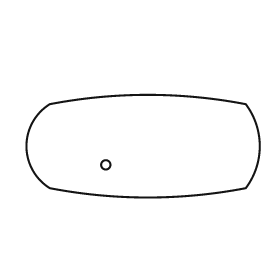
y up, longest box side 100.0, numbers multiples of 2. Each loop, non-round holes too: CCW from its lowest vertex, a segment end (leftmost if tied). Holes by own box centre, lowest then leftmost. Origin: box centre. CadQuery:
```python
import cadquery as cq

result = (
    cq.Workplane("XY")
    .moveTo(-40.0, -18.0)
    .threePointArc((2.0, -22.0), (44.0, -18.0))
    .threePointArc((50.0, 0.0), (44.0, 18.0))
    .threePointArc((2.0, 22.0), (-40.0, 18.0))
    .threePointArc((-50.0, 0.0), (-40.0, -18.0))
    .close()
    .moveTo(-16.0, -8.0)
    .circle(2.0)
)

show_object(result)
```